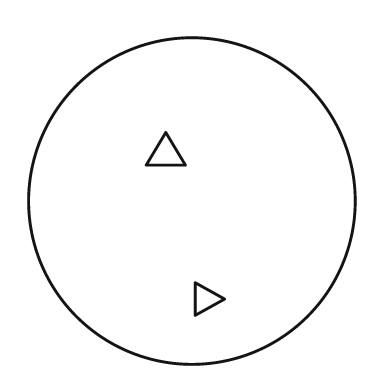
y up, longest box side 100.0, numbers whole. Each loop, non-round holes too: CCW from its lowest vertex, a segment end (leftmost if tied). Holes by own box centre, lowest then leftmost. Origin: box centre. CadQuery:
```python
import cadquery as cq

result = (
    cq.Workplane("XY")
    .moveTo(0.0, 0.0)
    .circle(50.0)
    .moveTo(1.0, -35.0)
    .lineTo(10.0, -30.0)
    .lineTo(1.0, -25.0)
    .close()
    .moveTo(-14.0, 11.0)
    .lineTo(-2.0, 11.0)
    .lineTo(-8.0, 21.0)
    .close()
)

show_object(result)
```